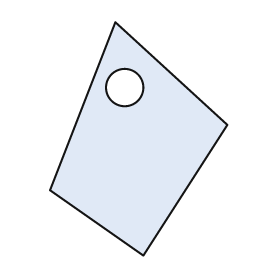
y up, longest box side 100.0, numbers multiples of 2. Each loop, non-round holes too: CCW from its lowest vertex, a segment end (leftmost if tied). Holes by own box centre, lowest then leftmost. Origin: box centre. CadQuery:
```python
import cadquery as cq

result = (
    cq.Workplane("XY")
    .moveTo(2.0, -50.0)
    .lineTo(38.0, 6.0)
    .lineTo(-10.0, 50.0)
    .lineTo(-38.0, -22.0)
    .close()
    .moveTo(-6.0, 22.0)
    .circle(8.0)
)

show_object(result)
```